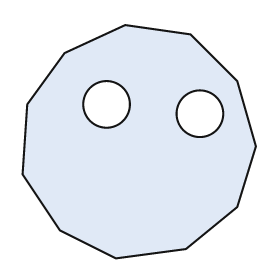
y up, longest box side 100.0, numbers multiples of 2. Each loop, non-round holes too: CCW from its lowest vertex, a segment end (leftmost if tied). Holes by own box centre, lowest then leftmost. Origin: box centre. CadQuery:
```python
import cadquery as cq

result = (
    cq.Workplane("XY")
    .moveTo(-10.0, -50.0)
    .lineTo(20.0, -46.0)
    .lineTo(42.0, -28.0)
    .lineTo(50.0, -2.0)
    .lineTo(42.0, 26.0)
    .lineTo(22.0, 46.0)
    .lineTo(-6.0, 50.0)
    .lineTo(-32.0, 38.0)
    .lineTo(-48.0, 16.0)
    .lineTo(-50.0, -14.0)
    .lineTo(-34.0, -38.0)
    .close()
    .moveTo(26.0, 12.0)
    .circle(10.0)
    .moveTo(-14.0, 16.0)
    .circle(10.0)
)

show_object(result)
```